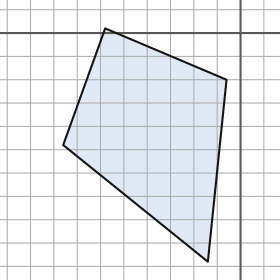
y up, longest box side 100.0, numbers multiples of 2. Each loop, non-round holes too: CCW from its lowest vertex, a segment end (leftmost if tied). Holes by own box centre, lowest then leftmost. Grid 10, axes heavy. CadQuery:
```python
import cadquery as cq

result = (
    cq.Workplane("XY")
    .moveTo(-14.0, -98.0)
    .lineTo(-6.0, -20.0)
    .lineTo(-58.0, 2.0)
    .lineTo(-76.0, -48.0)
    .close()
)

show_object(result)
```